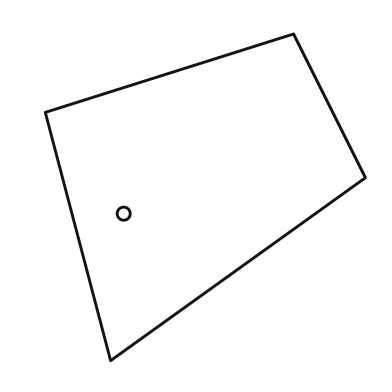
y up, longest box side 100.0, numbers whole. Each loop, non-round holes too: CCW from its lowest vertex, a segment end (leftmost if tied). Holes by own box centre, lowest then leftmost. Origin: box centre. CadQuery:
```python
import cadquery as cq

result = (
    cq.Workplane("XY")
    .moveTo(-29.0, -50.0)
    .lineTo(49.0, 6.0)
    .lineTo(27.0, 50.0)
    .lineTo(-49.0, 26.0)
    .close()
    .moveTo(-25.0, -5.0)
    .circle(2.0)
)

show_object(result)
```